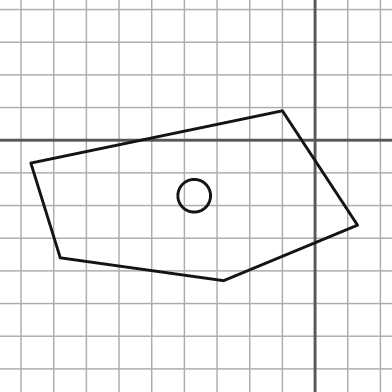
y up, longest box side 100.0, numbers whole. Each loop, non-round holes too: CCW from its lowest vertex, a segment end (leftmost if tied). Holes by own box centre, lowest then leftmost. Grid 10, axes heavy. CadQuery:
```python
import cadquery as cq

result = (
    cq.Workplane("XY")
    .moveTo(-28.0, -43.0)
    .lineTo(13.0, -26.0)
    .lineTo(-10.0, 9.0)
    .lineTo(-87.0, -7.0)
    .lineTo(-78.0, -36.0)
    .close()
    .moveTo(-37.0, -17.0)
    .circle(5.0)
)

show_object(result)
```